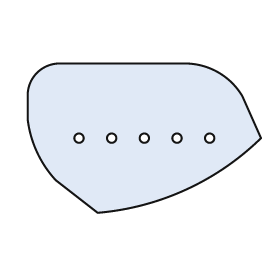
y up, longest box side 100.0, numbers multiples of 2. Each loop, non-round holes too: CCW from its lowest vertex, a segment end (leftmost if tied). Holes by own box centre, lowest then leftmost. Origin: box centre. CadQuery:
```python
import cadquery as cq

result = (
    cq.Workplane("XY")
    .moveTo(-20.0, -32.0)
    .threePointArc((18.0, -22.0), (50.0, 0.0))
    .lineTo(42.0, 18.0)
    .threePointArc((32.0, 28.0), (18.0, 32.0))
    .lineTo(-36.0, 32.0)
    .threePointArc((-46.0, 28.0), (-50.0, 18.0))
    .lineTo(-50.0, 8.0)
    .threePointArc((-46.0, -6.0), (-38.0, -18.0))
    .close()
    .moveTo(-28.0, 0.0)
    .circle(2.0)
    .moveTo(-14.0, 0.0)
    .circle(2.0)
    .moveTo(0.0, 0.0)
    .circle(2.0)
    .moveTo(14.0, 0.0)
    .circle(2.0)
    .moveTo(28.0, 0.0)
    .circle(2.0)
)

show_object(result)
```